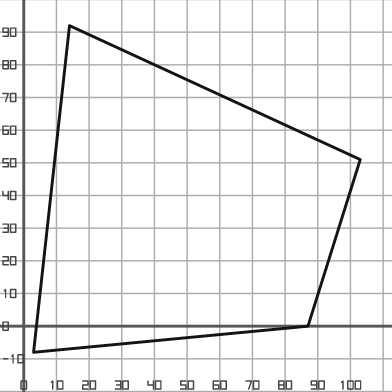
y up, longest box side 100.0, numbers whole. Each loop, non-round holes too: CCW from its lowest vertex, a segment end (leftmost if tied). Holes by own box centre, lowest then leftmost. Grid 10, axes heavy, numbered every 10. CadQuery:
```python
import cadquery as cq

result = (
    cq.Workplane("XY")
    .moveTo(3.0, -8.0)
    .lineTo(87.0, 0.0)
    .lineTo(103.0, 51.0)
    .lineTo(14.0, 92.0)
    .close()
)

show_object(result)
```